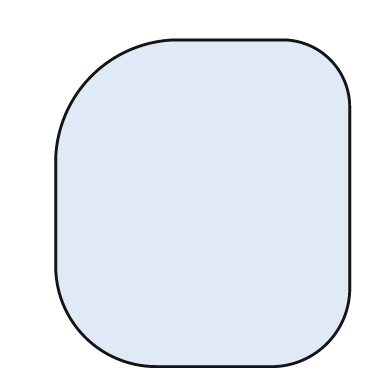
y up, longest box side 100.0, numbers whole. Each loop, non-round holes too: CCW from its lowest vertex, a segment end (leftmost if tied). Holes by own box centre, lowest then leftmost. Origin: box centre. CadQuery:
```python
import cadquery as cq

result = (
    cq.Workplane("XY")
    .moveTo(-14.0, -50.0)
    .lineTo(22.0, -50.0)
    .threePointArc((38.0, -43.0), (45.0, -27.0))
    .lineTo(45.0, 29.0)
    .threePointArc((39.0, 44.0), (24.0, 50.0))
    .lineTo(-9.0, 50.0)
    .threePointArc((-34.0, 39.0), (-45.0, 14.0))
    .lineTo(-45.0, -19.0)
    .threePointArc((-36.0, -41.0), (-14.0, -50.0))
    .close()
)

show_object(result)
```